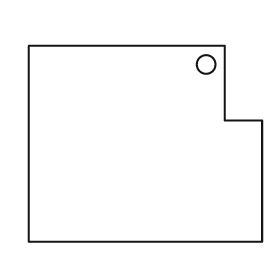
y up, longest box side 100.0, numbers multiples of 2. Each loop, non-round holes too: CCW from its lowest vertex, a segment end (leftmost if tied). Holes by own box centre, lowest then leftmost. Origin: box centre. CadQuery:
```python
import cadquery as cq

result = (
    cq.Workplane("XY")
    .moveTo(-50.0, -42.0)
    .lineTo(50.0, -42.0)
    .lineTo(50.0, 10.0)
    .lineTo(34.0, 10.0)
    .lineTo(34.0, 42.0)
    .lineTo(-50.0, 42.0)
    .close()
    .moveTo(26.0, 34.0)
    .circle(4.0)
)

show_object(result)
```